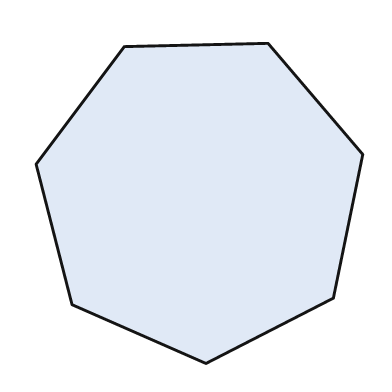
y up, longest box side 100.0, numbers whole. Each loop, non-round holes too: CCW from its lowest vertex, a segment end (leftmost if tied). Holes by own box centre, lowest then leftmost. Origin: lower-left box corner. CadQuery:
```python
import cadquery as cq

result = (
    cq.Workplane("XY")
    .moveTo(52.0, 0.0)
    .lineTo(91.0, 20.0)
    .lineTo(100.0, 64.0)
    .lineTo(71.0, 98.0)
    .lineTo(27.0, 97.0)
    .lineTo(0.0, 61.0)
    .lineTo(11.0, 18.0)
    .close()
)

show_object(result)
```